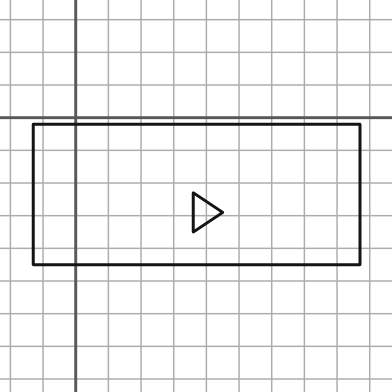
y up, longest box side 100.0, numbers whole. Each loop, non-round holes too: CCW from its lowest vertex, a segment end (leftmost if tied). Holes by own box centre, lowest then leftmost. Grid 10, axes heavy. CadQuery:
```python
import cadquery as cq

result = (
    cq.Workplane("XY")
    .moveTo(-13.0, -45.0)
    .lineTo(87.0, -45.0)
    .lineTo(87.0, -2.0)
    .lineTo(-13.0, -2.0)
    .close()
    .moveTo(36.0, -35.0)
    .lineTo(45.0, -29.0)
    .lineTo(36.0, -23.0)
    .close()
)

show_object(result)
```